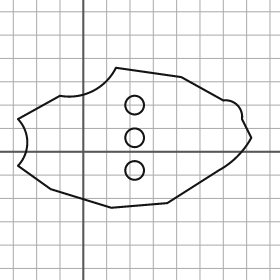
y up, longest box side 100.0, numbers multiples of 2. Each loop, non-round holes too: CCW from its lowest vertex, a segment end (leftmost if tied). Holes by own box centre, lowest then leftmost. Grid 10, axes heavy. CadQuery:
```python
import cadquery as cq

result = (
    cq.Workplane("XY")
    .moveTo(12.0, -24.0)
    .lineTo(36.0, -22.0)
    .lineTo(58.0, -8.0)
    .threePointArc((66.0, -2.0), (72.0, 6.0))
    .lineTo(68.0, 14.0)
    .threePointArc((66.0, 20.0), (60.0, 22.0))
    .lineTo(42.0, 32.0)
    .lineTo(14.0, 36.0)
    .threePointArc((4.0, 26.0), (-10.0, 24.0))
    .lineTo(-28.0, 14.0)
    .threePointArc((-24.0, 4.0), (-28.0, -6.0))
    .lineTo(-14.0, -16.0)
    .close()
    .moveTo(22.0, -8.0)
    .circle(4.0)
    .moveTo(22.0, 6.0)
    .circle(4.0)
    .moveTo(22.0, 20.0)
    .circle(4.0)
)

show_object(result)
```